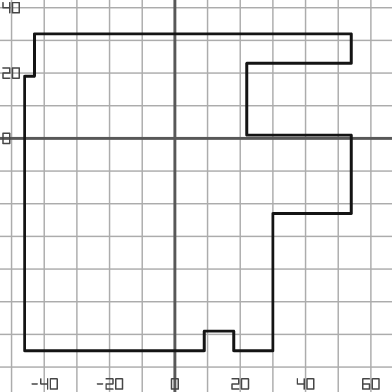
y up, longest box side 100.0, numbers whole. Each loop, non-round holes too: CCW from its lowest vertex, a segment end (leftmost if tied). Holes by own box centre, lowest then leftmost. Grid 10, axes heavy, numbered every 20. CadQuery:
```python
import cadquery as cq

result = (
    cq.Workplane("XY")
    .moveTo(-46.0, -65.0)
    .lineTo(9.0, -65.0)
    .lineTo(9.0, -59.0)
    .lineTo(18.0, -59.0)
    .lineTo(18.0, -65.0)
    .lineTo(30.0, -65.0)
    .lineTo(30.0, -23.0)
    .lineTo(54.0, -23.0)
    .lineTo(54.0, 1.0)
    .lineTo(22.0, 1.0)
    .lineTo(22.0, 23.0)
    .lineTo(54.0, 23.0)
    .lineTo(54.0, 32.0)
    .lineTo(-43.0, 32.0)
    .lineTo(-43.0, 19.0)
    .lineTo(-46.0, 19.0)
    .close()
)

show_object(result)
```